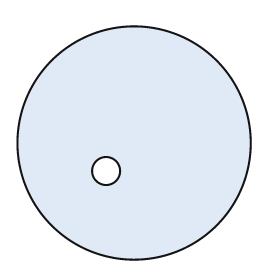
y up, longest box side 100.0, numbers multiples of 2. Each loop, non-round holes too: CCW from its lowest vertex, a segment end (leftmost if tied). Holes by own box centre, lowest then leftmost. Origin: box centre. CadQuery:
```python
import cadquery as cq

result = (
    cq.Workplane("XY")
    .moveTo(0.0, 0.0)
    .circle(50.0)
    .moveTo(-12.0, -12.0)
    .circle(6.0)
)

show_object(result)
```